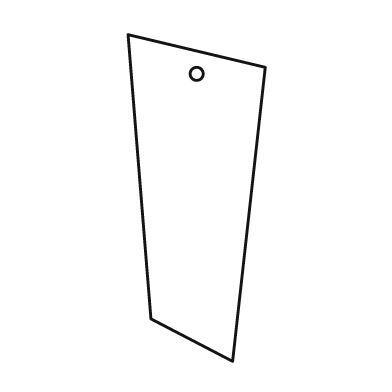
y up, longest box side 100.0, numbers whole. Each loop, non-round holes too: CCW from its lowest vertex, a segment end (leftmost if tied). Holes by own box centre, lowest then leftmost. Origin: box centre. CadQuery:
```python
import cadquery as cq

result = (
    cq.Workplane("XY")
    .moveTo(11.0, -50.0)
    .lineTo(21.0, 40.0)
    .lineTo(-21.0, 50.0)
    .lineTo(-14.0, -37.0)
    .close()
    .moveTo(0.0, 38.0)
    .circle(2.0)
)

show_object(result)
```